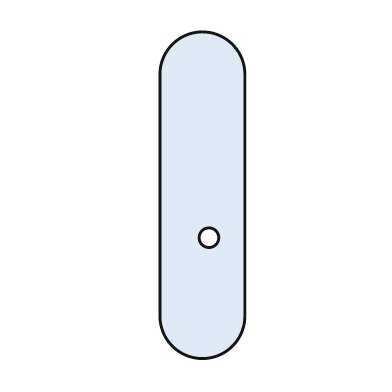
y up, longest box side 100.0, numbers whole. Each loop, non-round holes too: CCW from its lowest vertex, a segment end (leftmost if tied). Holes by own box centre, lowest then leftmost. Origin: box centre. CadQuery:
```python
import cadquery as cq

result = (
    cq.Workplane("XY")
    .moveTo(-13.0, -37.0)
    .threePointArc((0.0, -50.0), (13.0, -37.0))
    .lineTo(13.0, 37.0)
    .threePointArc((0.0, 50.0), (-13.0, 37.0))
    .close()
    .moveTo(2.0, -13.0)
    .circle(3.0)
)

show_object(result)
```